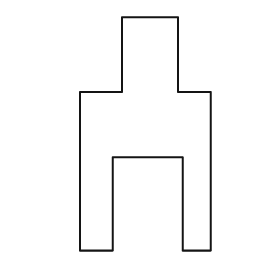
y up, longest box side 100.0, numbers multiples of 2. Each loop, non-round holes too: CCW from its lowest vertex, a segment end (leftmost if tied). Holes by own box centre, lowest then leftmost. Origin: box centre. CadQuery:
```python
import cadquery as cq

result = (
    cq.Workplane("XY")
    .moveTo(-28.0, -50.0)
    .lineTo(-14.0, -50.0)
    .lineTo(-14.0, -10.0)
    .lineTo(16.0, -10.0)
    .lineTo(16.0, -50.0)
    .lineTo(28.0, -50.0)
    .lineTo(28.0, 18.0)
    .lineTo(14.0, 18.0)
    .lineTo(14.0, 50.0)
    .lineTo(-10.0, 50.0)
    .lineTo(-10.0, 18.0)
    .lineTo(-28.0, 18.0)
    .close()
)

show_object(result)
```